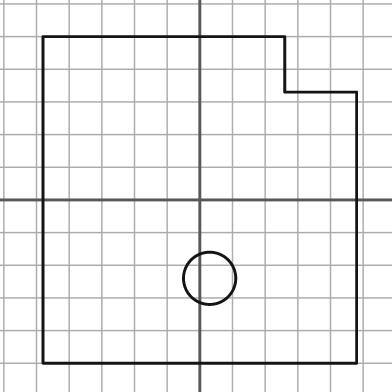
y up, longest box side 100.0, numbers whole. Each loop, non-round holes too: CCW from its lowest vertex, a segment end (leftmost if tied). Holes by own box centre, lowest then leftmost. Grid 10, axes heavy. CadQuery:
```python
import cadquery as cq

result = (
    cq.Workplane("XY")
    .moveTo(-48.0, -50.0)
    .lineTo(48.0, -50.0)
    .lineTo(48.0, 33.0)
    .lineTo(26.0, 33.0)
    .lineTo(26.0, 50.0)
    .lineTo(-48.0, 50.0)
    .close()
    .moveTo(3.0, -24.0)
    .circle(8.0)
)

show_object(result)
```